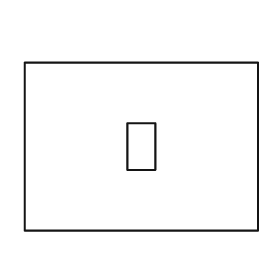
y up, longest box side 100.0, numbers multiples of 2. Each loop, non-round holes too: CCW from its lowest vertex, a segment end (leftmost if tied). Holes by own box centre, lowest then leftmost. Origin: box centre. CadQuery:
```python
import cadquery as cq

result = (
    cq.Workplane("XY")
    .moveTo(-50.0, -36.0)
    .lineTo(50.0, -36.0)
    .lineTo(50.0, 36.0)
    .lineTo(-50.0, 36.0)
    .close()
    .moveTo(-6.0, -10.0)
    .lineTo(6.0, -10.0)
    .lineTo(6.0, 10.0)
    .lineTo(-6.0, 10.0)
    .close()
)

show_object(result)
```